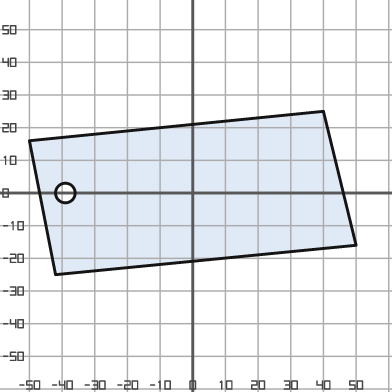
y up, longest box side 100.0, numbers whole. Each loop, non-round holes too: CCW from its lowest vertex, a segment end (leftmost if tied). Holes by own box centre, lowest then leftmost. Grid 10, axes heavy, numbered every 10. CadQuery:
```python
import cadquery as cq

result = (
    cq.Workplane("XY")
    .moveTo(-42.0, -25.0)
    .lineTo(50.0, -16.0)
    .lineTo(40.0, 25.0)
    .lineTo(-50.0, 16.0)
    .close()
    .moveTo(-39.0, 0.0)
    .circle(3.0)
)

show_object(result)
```